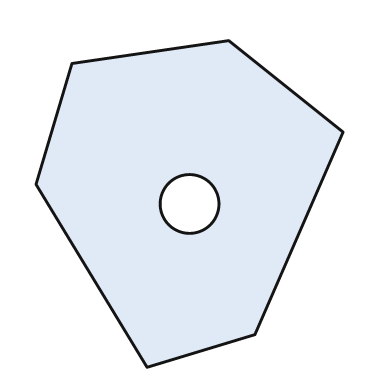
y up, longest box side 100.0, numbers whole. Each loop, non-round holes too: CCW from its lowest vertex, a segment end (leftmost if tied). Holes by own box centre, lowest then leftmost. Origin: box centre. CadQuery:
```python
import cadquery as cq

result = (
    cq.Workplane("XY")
    .moveTo(-13.0, -50.0)
    .lineTo(20.0, -40.0)
    .lineTo(47.0, 22.0)
    .lineTo(12.0, 50.0)
    .lineTo(-36.0, 43.0)
    .lineTo(-47.0, 6.0)
    .close()
    .moveTo(0.0, 0.0)
    .circle(9.0)
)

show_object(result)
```